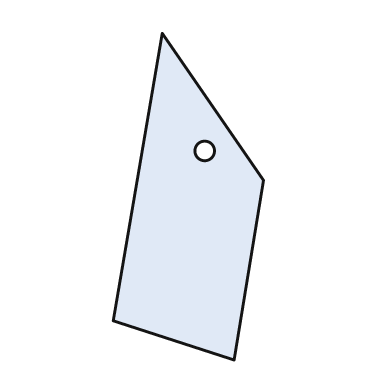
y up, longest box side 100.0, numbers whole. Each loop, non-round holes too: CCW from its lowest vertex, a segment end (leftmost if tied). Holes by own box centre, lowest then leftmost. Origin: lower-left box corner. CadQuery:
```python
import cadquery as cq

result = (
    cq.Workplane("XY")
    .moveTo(37.0, 0.0)
    .lineTo(46.0, 55.0)
    .lineTo(15.0, 100.0)
    .lineTo(0.0, 12.0)
    .close()
    .moveTo(28.0, 64.0)
    .circle(3.0)
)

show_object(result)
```